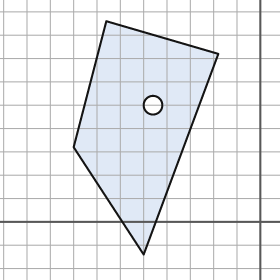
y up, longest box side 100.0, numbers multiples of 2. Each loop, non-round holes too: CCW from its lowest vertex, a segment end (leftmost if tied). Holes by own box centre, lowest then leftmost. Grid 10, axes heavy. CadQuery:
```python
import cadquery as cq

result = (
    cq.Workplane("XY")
    .moveTo(-50.0, -14.0)
    .lineTo(-18.0, 72.0)
    .lineTo(-66.0, 86.0)
    .lineTo(-80.0, 32.0)
    .close()
    .moveTo(-46.0, 50.0)
    .circle(4.0)
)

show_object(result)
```